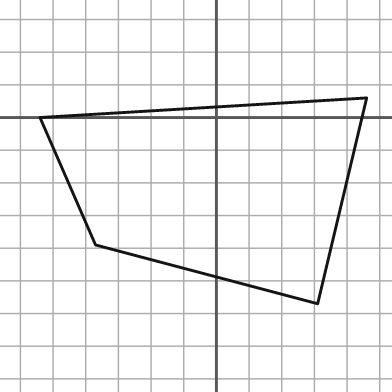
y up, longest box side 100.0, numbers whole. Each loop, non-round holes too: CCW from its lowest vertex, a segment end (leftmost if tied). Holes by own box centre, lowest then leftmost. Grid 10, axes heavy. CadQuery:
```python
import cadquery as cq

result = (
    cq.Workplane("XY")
    .moveTo(31.0, -57.0)
    .lineTo(46.0, 6.0)
    .lineTo(-54.0, 0.0)
    .lineTo(-37.0, -39.0)
    .close()
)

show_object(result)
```